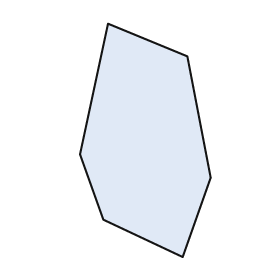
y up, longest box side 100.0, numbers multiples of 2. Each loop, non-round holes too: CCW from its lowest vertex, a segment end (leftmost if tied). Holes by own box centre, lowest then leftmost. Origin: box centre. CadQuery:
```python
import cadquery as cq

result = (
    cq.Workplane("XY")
    .moveTo(16.0, -50.0)
    .lineTo(28.0, -16.0)
    .lineTo(18.0, 36.0)
    .lineTo(-16.0, 50.0)
    .lineTo(-28.0, -6.0)
    .lineTo(-18.0, -34.0)
    .close()
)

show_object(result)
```